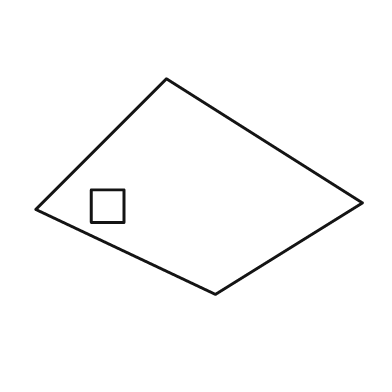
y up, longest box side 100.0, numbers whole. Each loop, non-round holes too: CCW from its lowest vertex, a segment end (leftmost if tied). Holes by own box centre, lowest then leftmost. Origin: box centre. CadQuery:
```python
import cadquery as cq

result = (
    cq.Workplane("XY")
    .moveTo(5.0, -33.0)
    .lineTo(50.0, -5.0)
    .lineTo(-10.0, 33.0)
    .lineTo(-50.0, -7.0)
    .close()
    .moveTo(-33.0, -11.0)
    .lineTo(-23.0, -11.0)
    .lineTo(-23.0, -1.0)
    .lineTo(-33.0, -1.0)
    .close()
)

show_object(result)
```